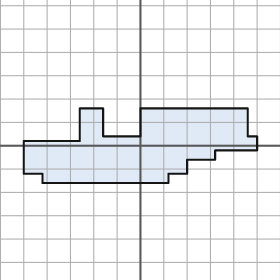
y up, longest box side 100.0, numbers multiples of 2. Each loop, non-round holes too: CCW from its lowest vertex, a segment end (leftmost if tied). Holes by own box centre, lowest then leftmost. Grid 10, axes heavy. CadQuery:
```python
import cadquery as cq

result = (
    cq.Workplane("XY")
    .moveTo(-42.0, -16.0)
    .lineTo(12.0, -16.0)
    .lineTo(12.0, -12.0)
    .lineTo(20.0, -12.0)
    .lineTo(20.0, -6.0)
    .lineTo(32.0, -6.0)
    .lineTo(32.0, -2.0)
    .lineTo(50.0, -2.0)
    .lineTo(50.0, 4.0)
    .lineTo(46.0, 4.0)
    .lineTo(46.0, 16.0)
    .lineTo(0.0, 16.0)
    .lineTo(0.0, 4.0)
    .lineTo(-16.0, 4.0)
    .lineTo(-16.0, 16.0)
    .lineTo(-26.0, 16.0)
    .lineTo(-26.0, 2.0)
    .lineTo(-50.0, 2.0)
    .lineTo(-50.0, -12.0)
    .lineTo(-42.0, -12.0)
    .close()
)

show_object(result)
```